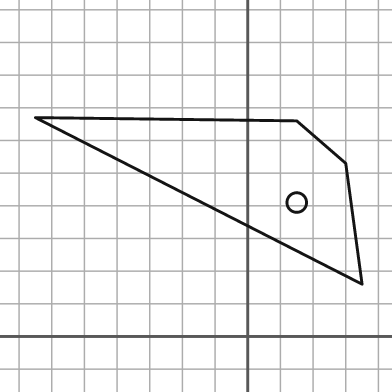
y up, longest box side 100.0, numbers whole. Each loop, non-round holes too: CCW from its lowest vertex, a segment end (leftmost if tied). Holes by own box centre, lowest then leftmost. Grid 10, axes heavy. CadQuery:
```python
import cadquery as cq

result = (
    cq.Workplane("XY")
    .moveTo(35.0, 16.0)
    .lineTo(30.0, 53.0)
    .lineTo(15.0, 66.0)
    .lineTo(-65.0, 67.0)
    .close()
    .moveTo(15.0, 41.0)
    .circle(3.0)
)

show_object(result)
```